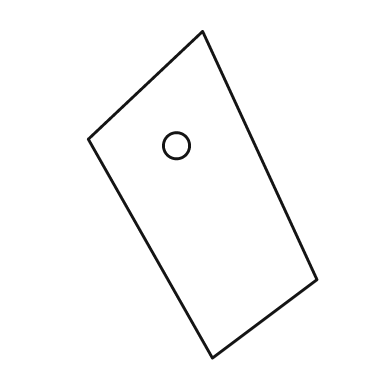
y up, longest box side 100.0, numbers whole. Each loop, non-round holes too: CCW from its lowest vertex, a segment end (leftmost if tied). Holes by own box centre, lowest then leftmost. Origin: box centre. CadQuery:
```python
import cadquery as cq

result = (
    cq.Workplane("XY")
    .moveTo(3.0, -50.0)
    .lineTo(35.0, -26.0)
    .lineTo(0.0, 50.0)
    .lineTo(-35.0, 17.0)
    .close()
    .moveTo(-8.0, 15.0)
    .circle(4.0)
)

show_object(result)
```